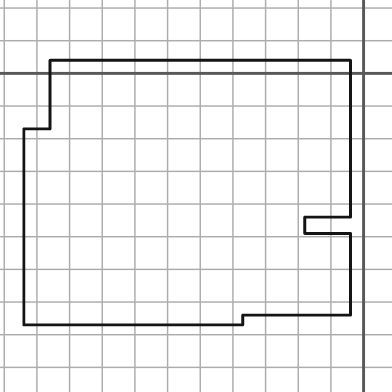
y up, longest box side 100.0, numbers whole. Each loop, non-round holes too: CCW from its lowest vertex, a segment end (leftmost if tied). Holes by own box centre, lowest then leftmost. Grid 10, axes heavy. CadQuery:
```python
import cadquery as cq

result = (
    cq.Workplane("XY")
    .moveTo(-104.0, -77.0)
    .lineTo(-37.0, -77.0)
    .lineTo(-37.0, -74.0)
    .lineTo(-4.0, -74.0)
    .lineTo(-4.0, -49.0)
    .lineTo(-18.0, -49.0)
    .lineTo(-18.0, -44.0)
    .lineTo(-4.0, -44.0)
    .lineTo(-4.0, 4.0)
    .lineTo(-96.0, 4.0)
    .lineTo(-96.0, -17.0)
    .lineTo(-104.0, -17.0)
    .close()
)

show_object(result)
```